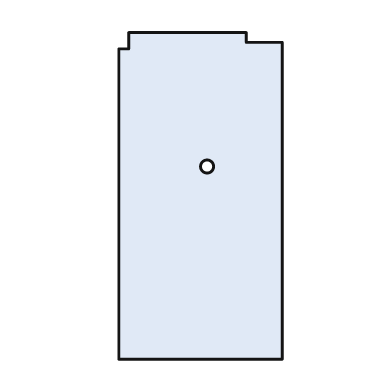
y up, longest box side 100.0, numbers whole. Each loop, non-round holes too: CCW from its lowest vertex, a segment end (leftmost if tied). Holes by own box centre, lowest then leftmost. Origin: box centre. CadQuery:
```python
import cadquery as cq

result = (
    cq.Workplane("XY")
    .moveTo(-25.0, -50.0)
    .lineTo(25.0, -50.0)
    .lineTo(25.0, 47.0)
    .lineTo(14.0, 47.0)
    .lineTo(14.0, 50.0)
    .lineTo(-22.0, 50.0)
    .lineTo(-22.0, 45.0)
    .lineTo(-25.0, 45.0)
    .close()
    .moveTo(2.0, 9.0)
    .circle(2.0)
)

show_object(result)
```